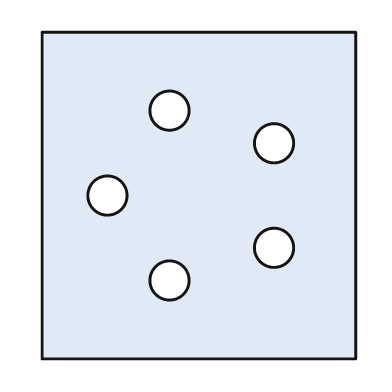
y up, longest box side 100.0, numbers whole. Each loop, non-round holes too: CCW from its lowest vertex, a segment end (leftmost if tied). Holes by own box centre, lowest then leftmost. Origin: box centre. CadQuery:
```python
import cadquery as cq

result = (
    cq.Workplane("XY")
    .moveTo(-48.0, -50.0)
    .lineTo(48.0, -50.0)
    .lineTo(48.0, 50.0)
    .lineTo(-48.0, 50.0)
    .close()
    .moveTo(-9.0, -26.0)
    .circle(6.0)
    .moveTo(23.0, -16.0)
    .circle(6.0)
    .moveTo(-28.0, 0.0)
    .circle(6.0)
    .moveTo(23.0, 16.0)
    .circle(6.0)
    .moveTo(-9.0, 26.0)
    .circle(6.0)
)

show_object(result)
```